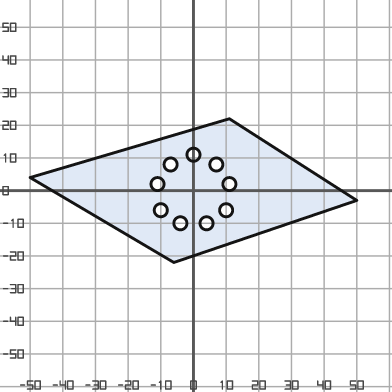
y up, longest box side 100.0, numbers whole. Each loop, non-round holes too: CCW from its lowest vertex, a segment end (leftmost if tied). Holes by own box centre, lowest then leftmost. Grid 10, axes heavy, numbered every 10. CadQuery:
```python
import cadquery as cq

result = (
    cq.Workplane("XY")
    .moveTo(-6.0, -22.0)
    .lineTo(50.0, -3.0)
    .lineTo(11.0, 22.0)
    .lineTo(-50.0, 4.0)
    .close()
    .moveTo(-4.0, -10.0)
    .circle(2.0)
    .moveTo(4.0, -10.0)
    .circle(2.0)
    .moveTo(-10.0, -6.0)
    .circle(2.0)
    .moveTo(10.0, -6.0)
    .circle(2.0)
    .moveTo(-11.0, 2.0)
    .circle(2.0)
    .moveTo(11.0, 2.0)
    .circle(2.0)
    .moveTo(-7.0, 8.0)
    .circle(2.0)
    .moveTo(7.0, 8.0)
    .circle(2.0)
    .moveTo(0.0, 11.0)
    .circle(2.0)
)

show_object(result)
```